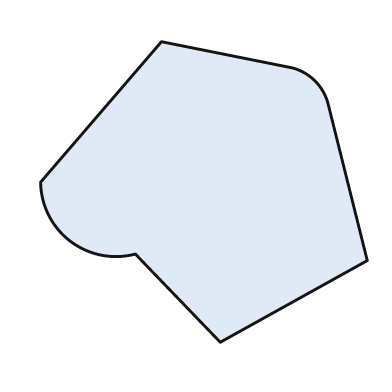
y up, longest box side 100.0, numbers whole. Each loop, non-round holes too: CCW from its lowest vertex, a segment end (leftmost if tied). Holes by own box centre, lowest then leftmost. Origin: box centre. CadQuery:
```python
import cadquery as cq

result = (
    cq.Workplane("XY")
    .moveTo(5.0, -46.0)
    .lineTo(50.0, -21.0)
    .lineTo(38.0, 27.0)
    .threePointArc((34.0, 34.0), (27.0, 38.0))
    .lineTo(-13.0, 46.0)
    .lineTo(-50.0, 3.0)
    .threePointArc((-41.0, -15.0), (-21.0, -19.0))
    .close()
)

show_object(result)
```